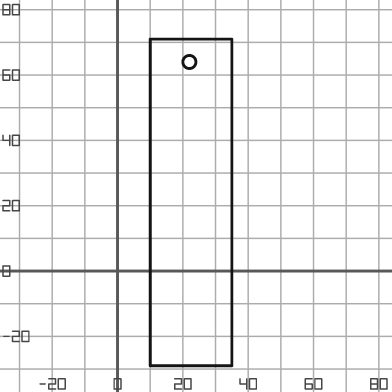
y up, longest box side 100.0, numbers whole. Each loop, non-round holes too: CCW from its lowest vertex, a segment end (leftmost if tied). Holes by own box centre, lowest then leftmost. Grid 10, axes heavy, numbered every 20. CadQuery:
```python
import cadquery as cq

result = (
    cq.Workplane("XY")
    .moveTo(10.0, -29.0)
    .lineTo(35.0, -29.0)
    .lineTo(35.0, 71.0)
    .lineTo(10.0, 71.0)
    .close()
    .moveTo(22.0, 64.0)
    .circle(2.0)
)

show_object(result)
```